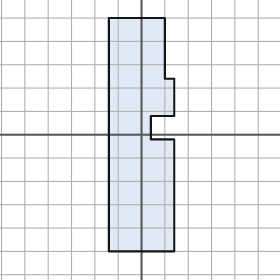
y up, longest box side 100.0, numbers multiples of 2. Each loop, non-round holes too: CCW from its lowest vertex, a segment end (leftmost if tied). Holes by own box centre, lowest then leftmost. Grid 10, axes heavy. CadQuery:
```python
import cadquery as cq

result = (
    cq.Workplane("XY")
    .moveTo(-14.0, -50.0)
    .lineTo(14.0, -50.0)
    .lineTo(14.0, -2.0)
    .lineTo(4.0, -2.0)
    .lineTo(4.0, 8.0)
    .lineTo(14.0, 8.0)
    .lineTo(14.0, 24.0)
    .lineTo(10.0, 24.0)
    .lineTo(10.0, 50.0)
    .lineTo(-14.0, 50.0)
    .close()
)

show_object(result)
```